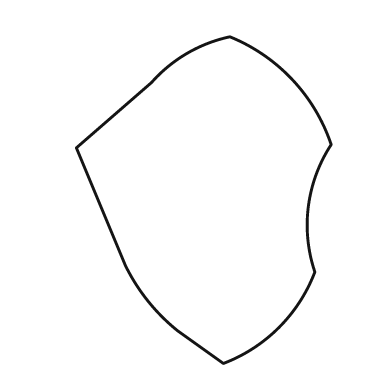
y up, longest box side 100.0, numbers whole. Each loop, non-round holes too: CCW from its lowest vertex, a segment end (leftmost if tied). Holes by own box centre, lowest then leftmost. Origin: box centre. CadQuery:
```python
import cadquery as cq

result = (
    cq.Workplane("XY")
    .moveTo(6.0, -50.0)
    .threePointArc((23.0, -39.0), (34.0, -22.0))
    .threePointArc((32.0, -2.0), (39.0, 17.0))
    .threePointArc((27.0, 37.0), (8.0, 50.0))
    .threePointArc((-5.0, 45.0), (-16.0, 36.0))
    .lineTo(-39.0, 16.0)
    .lineTo(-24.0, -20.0)
    .threePointArc((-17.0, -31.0), (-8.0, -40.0))
    .close()
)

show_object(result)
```